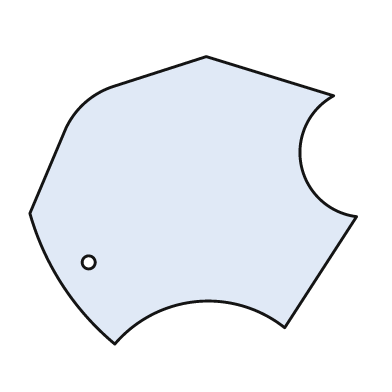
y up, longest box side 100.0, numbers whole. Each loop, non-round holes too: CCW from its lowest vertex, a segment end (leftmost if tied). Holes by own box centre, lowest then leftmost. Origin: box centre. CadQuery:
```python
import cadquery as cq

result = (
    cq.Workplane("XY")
    .moveTo(-24.0, -44.0)
    .threePointArc((1.0, -31.0), (28.0, -39.0))
    .lineTo(50.0, -5.0)
    .threePointArc((33.0, 11.0), (43.0, 32.0))
    .lineTo(4.0, 44.0)
    .lineTo(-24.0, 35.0)
    .threePointArc((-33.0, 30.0), (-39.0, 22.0))
    .lineTo(-50.0, -4.0)
    .threePointArc((-40.0, -26.0), (-24.0, -44.0))
    .close()
    .moveTo(-32.0, -19.0)
    .circle(2.0)
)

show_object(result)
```